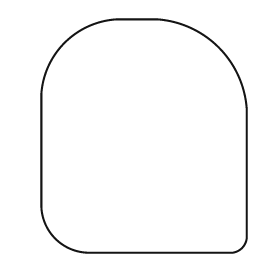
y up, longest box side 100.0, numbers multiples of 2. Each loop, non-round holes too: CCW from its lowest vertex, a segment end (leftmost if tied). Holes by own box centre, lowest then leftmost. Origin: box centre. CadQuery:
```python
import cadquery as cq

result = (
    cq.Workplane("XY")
    .moveTo(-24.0, -50.0)
    .lineTo(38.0, -50.0)
    .threePointArc((42.0, -48.0), (44.0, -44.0))
    .lineTo(44.0, 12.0)
    .threePointArc((32.0, 38.0), (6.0, 50.0))
    .lineTo(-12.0, 50.0)
    .threePointArc((-34.0, 40.0), (-44.0, 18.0))
    .lineTo(-44.0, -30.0)
    .threePointArc((-38.0, -44.0), (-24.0, -50.0))
    .close()
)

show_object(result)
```